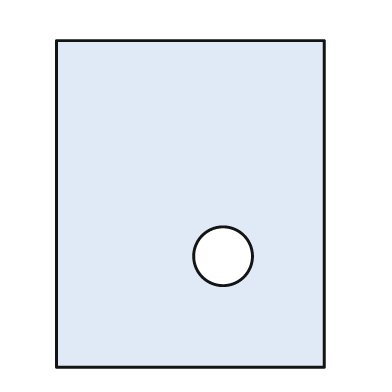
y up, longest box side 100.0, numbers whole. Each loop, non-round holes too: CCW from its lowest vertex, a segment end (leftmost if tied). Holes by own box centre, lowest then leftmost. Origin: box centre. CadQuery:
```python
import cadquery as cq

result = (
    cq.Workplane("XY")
    .moveTo(-41.0, -50.0)
    .lineTo(41.0, -50.0)
    .lineTo(41.0, 50.0)
    .lineTo(-41.0, 50.0)
    .close()
    .moveTo(10.0, -16.0)
    .circle(9.0)
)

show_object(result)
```